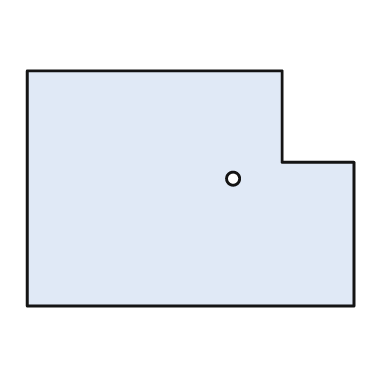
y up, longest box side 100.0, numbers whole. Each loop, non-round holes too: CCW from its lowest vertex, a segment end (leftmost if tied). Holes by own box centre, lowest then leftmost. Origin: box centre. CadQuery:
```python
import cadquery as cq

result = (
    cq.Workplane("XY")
    .moveTo(-50.0, -36.0)
    .lineTo(50.0, -36.0)
    .lineTo(50.0, 8.0)
    .lineTo(28.0, 8.0)
    .lineTo(28.0, 36.0)
    .lineTo(-50.0, 36.0)
    .close()
    .moveTo(13.0, 3.0)
    .circle(2.0)
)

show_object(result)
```